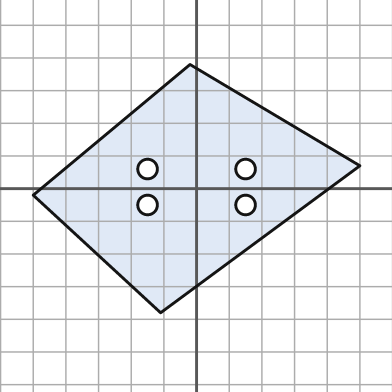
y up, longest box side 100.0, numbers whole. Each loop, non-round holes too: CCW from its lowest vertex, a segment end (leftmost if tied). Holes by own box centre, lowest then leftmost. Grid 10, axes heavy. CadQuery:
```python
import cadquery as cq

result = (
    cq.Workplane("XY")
    .moveTo(-11.0, -38.0)
    .lineTo(50.0, 7.0)
    .lineTo(-2.0, 38.0)
    .lineTo(-50.0, -2.0)
    .close()
    .moveTo(-15.0, -5.0)
    .circle(3.0)
    .moveTo(15.0, -5.0)
    .circle(3.0)
    .moveTo(-15.0, 6.0)
    .circle(3.0)
    .moveTo(15.0, 6.0)
    .circle(3.0)
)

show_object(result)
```